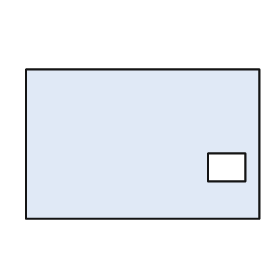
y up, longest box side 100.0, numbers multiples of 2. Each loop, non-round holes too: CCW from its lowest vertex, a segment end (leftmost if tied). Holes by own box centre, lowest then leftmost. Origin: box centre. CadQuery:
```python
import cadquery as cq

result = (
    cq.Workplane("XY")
    .moveTo(-50.0, -32.0)
    .lineTo(50.0, -32.0)
    .lineTo(50.0, 32.0)
    .lineTo(-50.0, 32.0)
    .close()
    .moveTo(28.0, -16.0)
    .lineTo(44.0, -16.0)
    .lineTo(44.0, -4.0)
    .lineTo(28.0, -4.0)
    .close()
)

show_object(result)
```